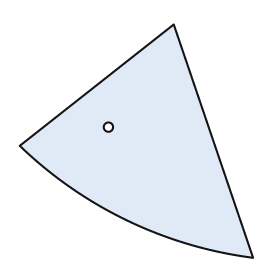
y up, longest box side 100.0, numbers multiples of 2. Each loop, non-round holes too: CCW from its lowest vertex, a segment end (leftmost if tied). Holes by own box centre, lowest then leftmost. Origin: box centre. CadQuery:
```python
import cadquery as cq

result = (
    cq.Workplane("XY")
    .moveTo(50.0, -50.0)
    .lineTo(16.0, 50.0)
    .lineTo(-50.0, -2.0)
    .threePointArc((-4.0, -34.0), (50.0, -50.0))
    .close()
    .moveTo(-12.0, 6.0)
    .circle(2.0)
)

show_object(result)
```